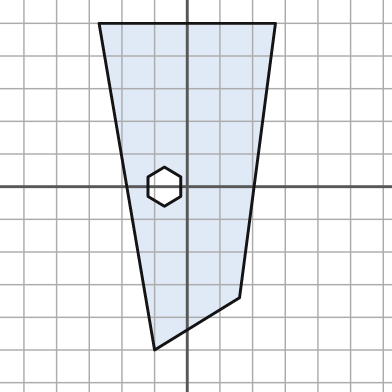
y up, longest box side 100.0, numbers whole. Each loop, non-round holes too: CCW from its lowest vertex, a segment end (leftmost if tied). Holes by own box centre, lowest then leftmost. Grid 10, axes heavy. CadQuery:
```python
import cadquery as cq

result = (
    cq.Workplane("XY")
    .moveTo(-10.0, -50.0)
    .lineTo(16.0, -34.0)
    .lineTo(27.0, 50.0)
    .lineTo(-27.0, 50.0)
    .close()
    .moveTo(-7.0, -6.0)
    .lineTo(-2.0, -3.0)
    .lineTo(-2.0, 3.0)
    .lineTo(-7.0, 6.0)
    .lineTo(-12.0, 3.0)
    .lineTo(-12.0, -3.0)
    .close()
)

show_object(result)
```